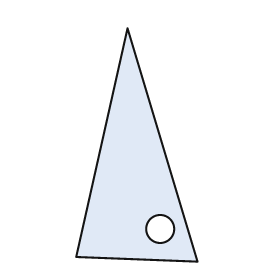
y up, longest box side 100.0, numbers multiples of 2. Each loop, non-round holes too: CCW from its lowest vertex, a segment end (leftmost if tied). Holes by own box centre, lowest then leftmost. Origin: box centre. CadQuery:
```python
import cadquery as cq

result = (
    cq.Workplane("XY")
    .moveTo(26.0, -50.0)
    .lineTo(-4.0, 50.0)
    .lineTo(-26.0, -48.0)
    .close()
    .moveTo(10.0, -36.0)
    .circle(6.0)
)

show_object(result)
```